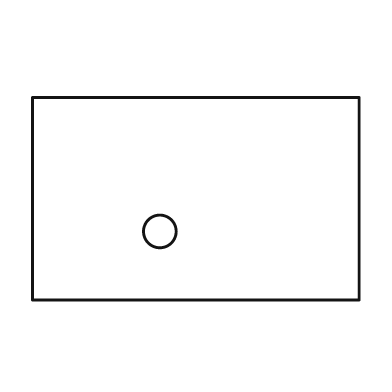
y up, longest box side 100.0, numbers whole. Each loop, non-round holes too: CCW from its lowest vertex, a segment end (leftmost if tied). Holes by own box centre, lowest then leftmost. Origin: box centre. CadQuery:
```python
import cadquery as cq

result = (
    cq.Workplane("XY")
    .moveTo(-50.0, -31.0)
    .lineTo(50.0, -31.0)
    .lineTo(50.0, 31.0)
    .lineTo(-50.0, 31.0)
    .close()
    .moveTo(-11.0, -10.0)
    .circle(5.0)
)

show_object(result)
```